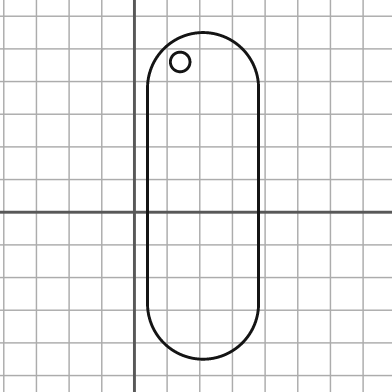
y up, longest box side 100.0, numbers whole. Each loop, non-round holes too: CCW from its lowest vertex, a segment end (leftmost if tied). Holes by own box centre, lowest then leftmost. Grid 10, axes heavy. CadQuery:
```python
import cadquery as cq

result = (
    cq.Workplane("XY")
    .moveTo(4.0, -28.0)
    .threePointArc((21.0, -45.0), (38.0, -28.0))
    .lineTo(38.0, 38.0)
    .threePointArc((21.0, 55.0), (4.0, 38.0))
    .close()
    .moveTo(14.0, 46.0)
    .circle(3.0)
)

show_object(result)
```